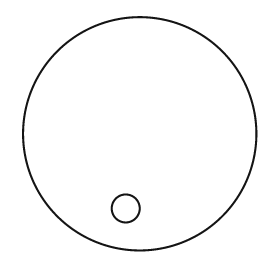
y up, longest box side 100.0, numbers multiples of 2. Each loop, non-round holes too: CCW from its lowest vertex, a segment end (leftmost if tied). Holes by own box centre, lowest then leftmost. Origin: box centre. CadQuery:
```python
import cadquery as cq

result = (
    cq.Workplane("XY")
    .moveTo(0.0, 0.0)
    .circle(50.0)
    .moveTo(-6.0, -32.0)
    .circle(6.0)
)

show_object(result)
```